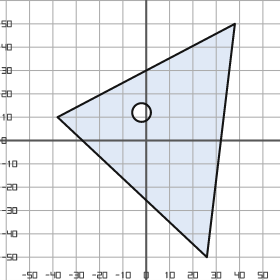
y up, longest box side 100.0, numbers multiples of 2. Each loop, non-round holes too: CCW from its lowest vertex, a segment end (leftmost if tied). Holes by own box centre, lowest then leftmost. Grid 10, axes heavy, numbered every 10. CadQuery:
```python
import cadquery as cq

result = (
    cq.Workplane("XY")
    .moveTo(26.0, -50.0)
    .lineTo(38.0, 50.0)
    .lineTo(-38.0, 10.0)
    .close()
    .moveTo(-2.0, 12.0)
    .circle(4.0)
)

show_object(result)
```